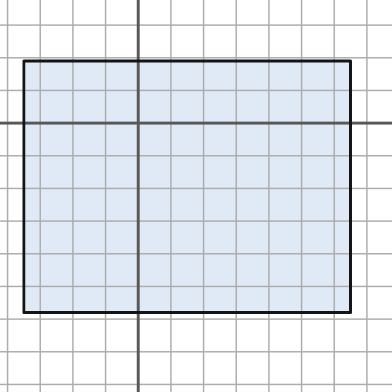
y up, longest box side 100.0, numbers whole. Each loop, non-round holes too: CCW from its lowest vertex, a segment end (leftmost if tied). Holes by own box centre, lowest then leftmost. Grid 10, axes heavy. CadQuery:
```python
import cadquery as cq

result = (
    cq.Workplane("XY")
    .moveTo(-35.0, -58.0)
    .lineTo(65.0, -58.0)
    .lineTo(65.0, 19.0)
    .lineTo(-35.0, 19.0)
    .close()
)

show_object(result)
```